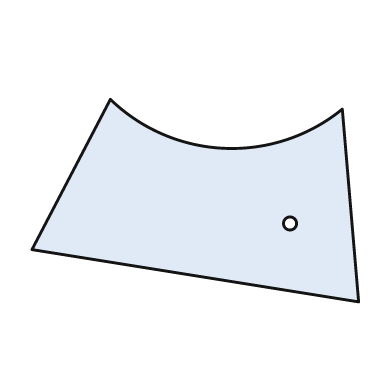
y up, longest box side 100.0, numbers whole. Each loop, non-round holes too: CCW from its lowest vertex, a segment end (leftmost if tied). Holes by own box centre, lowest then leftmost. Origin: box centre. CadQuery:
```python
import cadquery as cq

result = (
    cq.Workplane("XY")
    .moveTo(50.0, -31.0)
    .lineTo(45.0, 28.0)
    .threePointArc((9.0, 16.0), (-26.0, 31.0))
    .lineTo(-50.0, -15.0)
    .close()
    .moveTo(29.0, -7.0)
    .circle(2.0)
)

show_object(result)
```